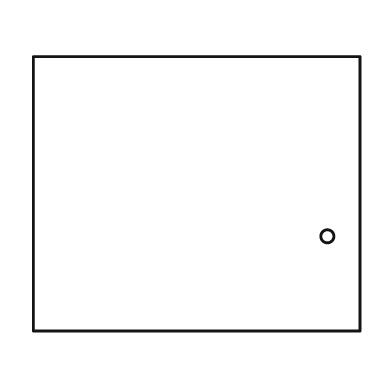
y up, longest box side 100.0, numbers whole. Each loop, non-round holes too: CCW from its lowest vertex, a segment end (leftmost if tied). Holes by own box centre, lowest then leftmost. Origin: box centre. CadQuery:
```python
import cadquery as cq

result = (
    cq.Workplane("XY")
    .moveTo(-50.0, -42.0)
    .lineTo(50.0, -42.0)
    .lineTo(50.0, 42.0)
    .lineTo(-50.0, 42.0)
    .close()
    .moveTo(40.0, -13.0)
    .circle(2.0)
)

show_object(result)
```